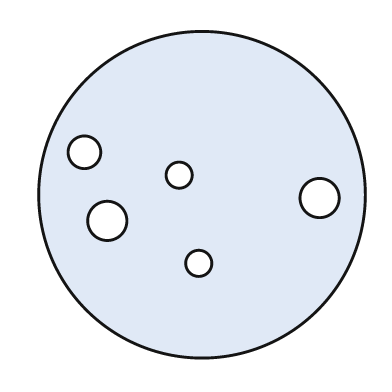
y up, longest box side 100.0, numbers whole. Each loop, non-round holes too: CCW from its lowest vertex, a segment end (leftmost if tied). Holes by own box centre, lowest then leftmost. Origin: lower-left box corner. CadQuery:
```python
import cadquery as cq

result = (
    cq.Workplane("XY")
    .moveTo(50.0, 50.0)
    .circle(50.0)
    .moveTo(49.0, 29.0)
    .circle(4.0)
    .moveTo(21.0, 42.0)
    .circle(6.0)
    .moveTo(86.0, 49.0)
    .circle(6.0)
    .moveTo(43.0, 56.0)
    .circle(4.0)
    .moveTo(14.0, 63.0)
    .circle(5.0)
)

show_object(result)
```